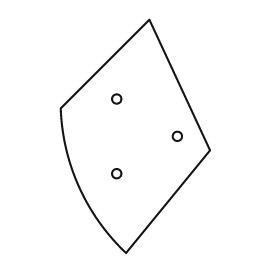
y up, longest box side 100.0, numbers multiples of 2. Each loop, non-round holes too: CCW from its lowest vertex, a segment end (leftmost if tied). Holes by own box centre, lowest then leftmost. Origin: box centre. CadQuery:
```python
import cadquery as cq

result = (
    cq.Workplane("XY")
    .moveTo(-4.0, -50.0)
    .lineTo(32.0, -6.0)
    .lineTo(6.0, 50.0)
    .lineTo(-32.0, 12.0)
    .threePointArc((-24.0, -22.0), (-4.0, -50.0))
    .close()
    .moveTo(-8.0, -16.0)
    .circle(2.0)
    .moveTo(18.0, 0.0)
    .circle(2.0)
    .moveTo(-8.0, 16.0)
    .circle(2.0)
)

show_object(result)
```